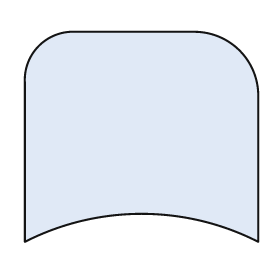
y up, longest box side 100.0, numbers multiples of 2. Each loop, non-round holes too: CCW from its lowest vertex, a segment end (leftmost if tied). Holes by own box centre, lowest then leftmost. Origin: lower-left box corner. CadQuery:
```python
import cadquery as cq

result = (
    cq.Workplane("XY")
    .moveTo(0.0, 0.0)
    .threePointArc((50.0, 12.0), (100.0, 0.0))
    .lineTo(100.0, 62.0)
    .threePointArc((92.0, 82.0), (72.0, 90.0))
    .lineTo(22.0, 90.0)
    .threePointArc((6.0, 84.0), (0.0, 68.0))
    .close()
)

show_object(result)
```